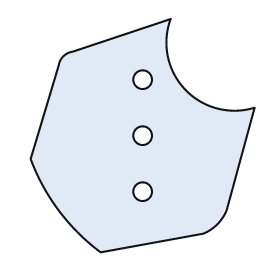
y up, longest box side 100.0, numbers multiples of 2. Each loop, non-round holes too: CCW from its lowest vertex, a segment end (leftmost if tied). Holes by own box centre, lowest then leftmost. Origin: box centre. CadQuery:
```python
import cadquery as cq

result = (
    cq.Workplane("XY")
    .moveTo(-18.0, -50.0)
    .lineTo(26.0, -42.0)
    .threePointArc((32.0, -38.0), (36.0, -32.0))
    .lineTo(48.0, 12.0)
    .threePointArc((18.0, 20.0), (12.0, 50.0))
    .lineTo(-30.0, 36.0)
    .threePointArc((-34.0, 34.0), (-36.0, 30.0))
    .lineTo(-48.0, -10.0)
    .threePointArc((-36.0, -32.0), (-18.0, -50.0))
    .close()
    .moveTo(0.0, -24.0)
    .circle(4.0)
    .moveTo(0.0, 0.0)
    .circle(4.0)
    .moveTo(0.0, 24.0)
    .circle(4.0)
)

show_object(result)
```